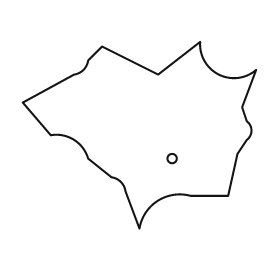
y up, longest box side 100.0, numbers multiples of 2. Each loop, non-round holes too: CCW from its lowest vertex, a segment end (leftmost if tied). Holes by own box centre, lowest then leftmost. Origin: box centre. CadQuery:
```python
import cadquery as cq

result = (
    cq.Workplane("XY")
    .moveTo(0.0, -40.0)
    .threePointArc((8.0, -28.0), (22.0, -26.0))
    .lineTo(38.0, -26.0)
    .lineTo(42.0, -8.0)
    .lineTo(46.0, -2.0)
    .threePointArc((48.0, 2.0), (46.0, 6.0))
    .lineTo(44.0, 12.0)
    .lineTo(50.0, 28.0)
    .threePointArc((34.0, 26.0), (26.0, 40.0))
    .lineTo(8.0, 26.0)
    .lineTo(-16.0, 38.0)
    .lineTo(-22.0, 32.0)
    .threePointArc((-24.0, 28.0), (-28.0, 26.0))
    .lineTo(-50.0, 14.0)
    .lineTo(-38.0, 0.0)
    .threePointArc((-28.0, -2.0), (-22.0, -10.0))
    .lineTo(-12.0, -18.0)
    .threePointArc((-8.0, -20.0), (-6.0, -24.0))
    .close()
    .moveTo(14.0, -10.0)
    .circle(2.0)
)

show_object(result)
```